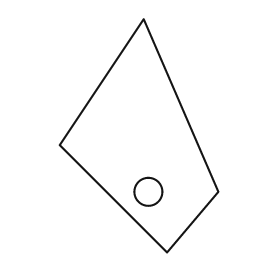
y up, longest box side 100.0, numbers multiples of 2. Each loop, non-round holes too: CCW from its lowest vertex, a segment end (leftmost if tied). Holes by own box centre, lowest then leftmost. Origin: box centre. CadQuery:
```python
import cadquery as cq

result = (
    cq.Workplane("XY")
    .moveTo(12.0, -50.0)
    .lineTo(34.0, -24.0)
    .lineTo(2.0, 50.0)
    .lineTo(-34.0, -4.0)
    .close()
    .moveTo(4.0, -24.0)
    .circle(6.0)
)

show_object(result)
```